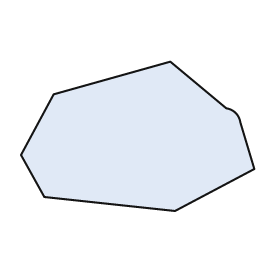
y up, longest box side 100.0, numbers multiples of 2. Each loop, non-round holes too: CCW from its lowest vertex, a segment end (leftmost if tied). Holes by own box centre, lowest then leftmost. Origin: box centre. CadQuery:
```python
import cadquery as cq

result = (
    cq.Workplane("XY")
    .moveTo(16.0, -32.0)
    .lineTo(50.0, -14.0)
    .lineTo(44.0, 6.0)
    .threePointArc((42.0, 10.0), (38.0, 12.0))
    .lineTo(14.0, 32.0)
    .lineTo(-36.0, 18.0)
    .lineTo(-50.0, -8.0)
    .lineTo(-40.0, -26.0)
    .close()
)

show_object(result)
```